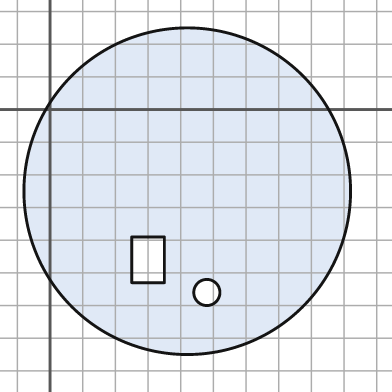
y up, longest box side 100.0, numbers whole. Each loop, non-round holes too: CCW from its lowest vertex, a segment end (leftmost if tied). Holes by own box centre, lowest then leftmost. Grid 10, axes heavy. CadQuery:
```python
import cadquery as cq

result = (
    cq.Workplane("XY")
    .moveTo(42.0, -25.0)
    .circle(50.0)
    .moveTo(48.0, -56.0)
    .circle(4.0)
    .moveTo(25.0, -53.0)
    .lineTo(35.0, -53.0)
    .lineTo(35.0, -39.0)
    .lineTo(25.0, -39.0)
    .close()
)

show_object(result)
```